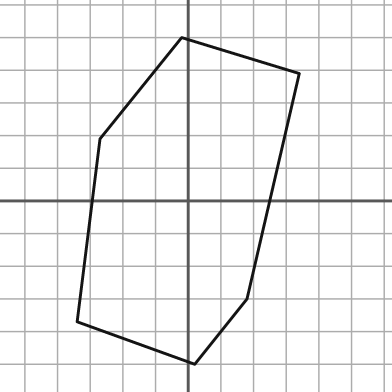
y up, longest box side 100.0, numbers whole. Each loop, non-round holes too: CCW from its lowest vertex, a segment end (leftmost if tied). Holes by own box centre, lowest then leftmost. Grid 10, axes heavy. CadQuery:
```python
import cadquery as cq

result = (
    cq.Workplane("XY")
    .moveTo(2.0, -50.0)
    .lineTo(18.0, -30.0)
    .lineTo(34.0, 39.0)
    .lineTo(-2.0, 50.0)
    .lineTo(-27.0, 19.0)
    .lineTo(-34.0, -37.0)
    .close()
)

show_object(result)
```